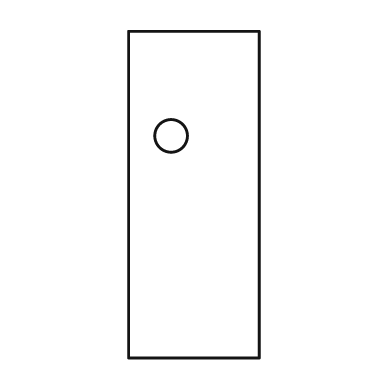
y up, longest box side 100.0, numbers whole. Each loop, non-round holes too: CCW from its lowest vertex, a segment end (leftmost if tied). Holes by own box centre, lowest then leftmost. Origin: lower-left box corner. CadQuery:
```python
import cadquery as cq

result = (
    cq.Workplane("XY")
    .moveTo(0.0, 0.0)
    .lineTo(40.0, 0.0)
    .lineTo(40.0, 100.0)
    .lineTo(0.0, 100.0)
    .close()
    .moveTo(13.0, 68.0)
    .circle(5.0)
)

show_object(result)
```